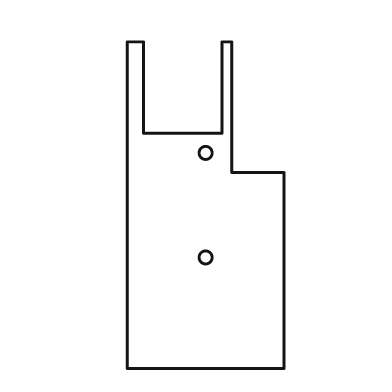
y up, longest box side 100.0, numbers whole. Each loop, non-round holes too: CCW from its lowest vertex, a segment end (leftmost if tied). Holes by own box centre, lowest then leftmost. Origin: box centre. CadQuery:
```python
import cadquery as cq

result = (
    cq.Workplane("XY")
    .moveTo(-24.0, -50.0)
    .lineTo(24.0, -50.0)
    .lineTo(24.0, 10.0)
    .lineTo(8.0, 10.0)
    .lineTo(8.0, 50.0)
    .lineTo(5.0, 50.0)
    .lineTo(5.0, 22.0)
    .lineTo(-19.0, 22.0)
    .lineTo(-19.0, 50.0)
    .lineTo(-24.0, 50.0)
    .close()
    .moveTo(0.0, -16.0)
    .circle(2.0)
    .moveTo(0.0, 16.0)
    .circle(2.0)
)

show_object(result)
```